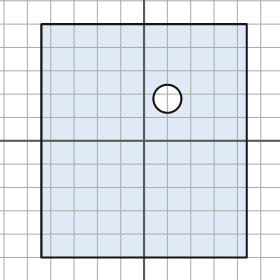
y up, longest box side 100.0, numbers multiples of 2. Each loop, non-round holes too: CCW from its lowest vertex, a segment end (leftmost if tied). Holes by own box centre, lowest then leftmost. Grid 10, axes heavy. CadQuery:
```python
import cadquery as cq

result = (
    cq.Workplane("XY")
    .moveTo(-44.0, -50.0)
    .lineTo(44.0, -50.0)
    .lineTo(44.0, 50.0)
    .lineTo(-44.0, 50.0)
    .close()
    .moveTo(10.0, 18.0)
    .circle(6.0)
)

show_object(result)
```